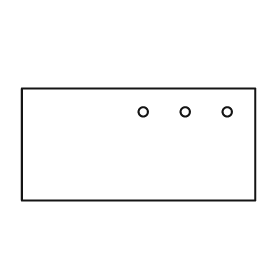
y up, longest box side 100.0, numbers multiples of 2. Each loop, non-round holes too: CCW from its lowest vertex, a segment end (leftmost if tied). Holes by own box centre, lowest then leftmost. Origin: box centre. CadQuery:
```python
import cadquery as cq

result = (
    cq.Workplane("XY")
    .moveTo(-50.0, -24.0)
    .lineTo(50.0, -24.0)
    .lineTo(50.0, 24.0)
    .lineTo(-50.0, 24.0)
    .close()
    .moveTo(2.0, 14.0)
    .circle(2.0)
    .moveTo(20.0, 14.0)
    .circle(2.0)
    .moveTo(38.0, 14.0)
    .circle(2.0)
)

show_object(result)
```